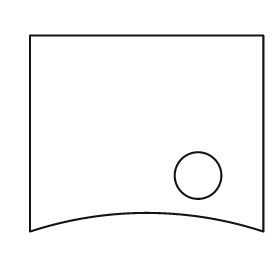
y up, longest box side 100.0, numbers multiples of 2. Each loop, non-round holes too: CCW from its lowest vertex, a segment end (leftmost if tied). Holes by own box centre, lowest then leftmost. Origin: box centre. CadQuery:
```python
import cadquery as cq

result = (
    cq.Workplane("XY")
    .moveTo(-50.0, -42.0)
    .threePointArc((0.0, -34.0), (50.0, -42.0))
    .lineTo(50.0, 42.0)
    .lineTo(-50.0, 42.0)
    .close()
    .moveTo(22.0, -18.0)
    .circle(10.0)
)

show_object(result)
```